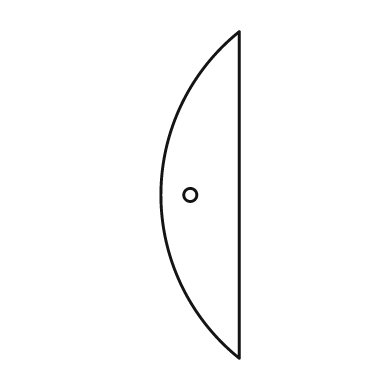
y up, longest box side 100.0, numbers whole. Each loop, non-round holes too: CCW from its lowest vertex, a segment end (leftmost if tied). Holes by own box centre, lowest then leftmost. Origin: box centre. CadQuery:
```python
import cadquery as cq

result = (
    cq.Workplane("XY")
    .moveTo(12.0, -50.0)
    .lineTo(12.0, 50.0)
    .threePointArc((-12.0, 0.0), (12.0, -50.0))
    .close()
    .moveTo(-3.0, 0.0)
    .circle(2.0)
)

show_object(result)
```